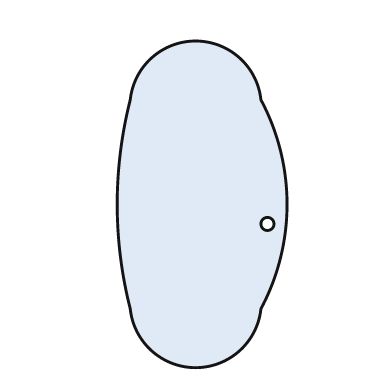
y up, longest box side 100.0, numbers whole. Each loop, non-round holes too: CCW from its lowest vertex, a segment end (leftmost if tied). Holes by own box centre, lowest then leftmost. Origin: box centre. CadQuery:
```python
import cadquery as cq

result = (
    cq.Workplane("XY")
    .moveTo(-22.0, -32.0)
    .threePointArc((-2.0, -50.0), (18.0, -32.0))
    .threePointArc((26.0, 0.0), (18.0, 32.0))
    .threePointArc((-2.0, 50.0), (-22.0, 32.0))
    .threePointArc((-26.0, 0.0), (-22.0, -32.0))
    .close()
    .moveTo(20.0, -6.0)
    .circle(2.0)
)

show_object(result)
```